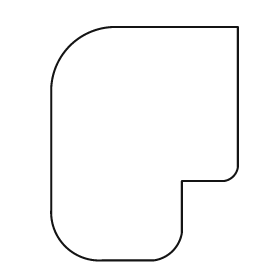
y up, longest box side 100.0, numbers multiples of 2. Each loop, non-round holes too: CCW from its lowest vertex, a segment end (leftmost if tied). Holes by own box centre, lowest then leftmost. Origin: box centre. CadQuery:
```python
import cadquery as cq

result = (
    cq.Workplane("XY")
    .moveTo(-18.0, -50.0)
    .lineTo(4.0, -50.0)
    .threePointArc((12.0, -46.0), (16.0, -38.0))
    .lineTo(16.0, -16.0)
    .lineTo(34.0, -16.0)
    .threePointArc((38.0, -14.0), (40.0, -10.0))
    .lineTo(40.0, 50.0)
    .lineTo(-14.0, 50.0)
    .threePointArc((-32.0, 42.0), (-40.0, 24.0))
    .lineTo(-40.0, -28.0)
    .threePointArc((-34.0, -44.0), (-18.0, -50.0))
    .close()
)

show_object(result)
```